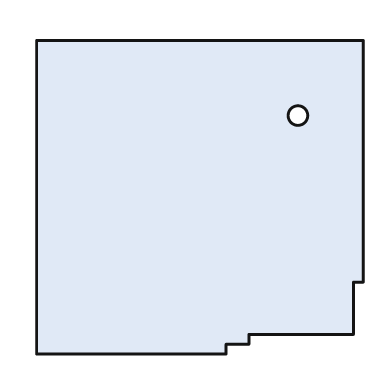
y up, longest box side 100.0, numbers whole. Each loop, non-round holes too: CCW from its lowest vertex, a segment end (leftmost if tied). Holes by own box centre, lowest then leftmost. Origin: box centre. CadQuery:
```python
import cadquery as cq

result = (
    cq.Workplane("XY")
    .moveTo(-50.0, -48.0)
    .lineTo(8.0, -48.0)
    .lineTo(8.0, -45.0)
    .lineTo(15.0, -45.0)
    .lineTo(15.0, -42.0)
    .lineTo(47.0, -42.0)
    .lineTo(47.0, -26.0)
    .lineTo(50.0, -26.0)
    .lineTo(50.0, 48.0)
    .lineTo(-50.0, 48.0)
    .close()
    .moveTo(30.0, 25.0)
    .circle(3.0)
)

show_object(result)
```